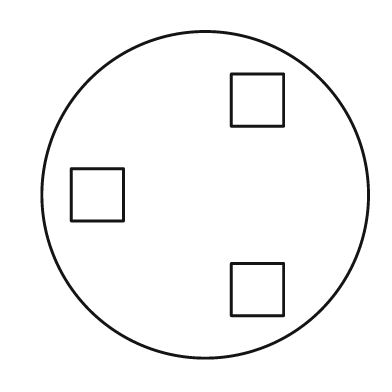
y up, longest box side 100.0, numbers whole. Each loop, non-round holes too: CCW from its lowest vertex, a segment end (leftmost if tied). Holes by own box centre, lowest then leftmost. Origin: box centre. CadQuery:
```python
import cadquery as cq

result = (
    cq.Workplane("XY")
    .moveTo(0.0, 0.0)
    .circle(50.0)
    .moveTo(8.0, -37.0)
    .lineTo(24.0, -37.0)
    .lineTo(24.0, -21.0)
    .lineTo(8.0, -21.0)
    .close()
    .moveTo(-41.0, -8.0)
    .lineTo(-25.0, -8.0)
    .lineTo(-25.0, 8.0)
    .lineTo(-41.0, 8.0)
    .close()
    .moveTo(8.0, 21.0)
    .lineTo(24.0, 21.0)
    .lineTo(24.0, 37.0)
    .lineTo(8.0, 37.0)
    .close()
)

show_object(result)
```